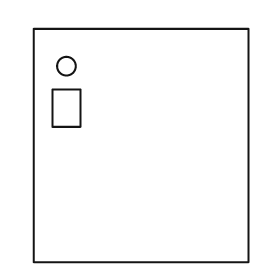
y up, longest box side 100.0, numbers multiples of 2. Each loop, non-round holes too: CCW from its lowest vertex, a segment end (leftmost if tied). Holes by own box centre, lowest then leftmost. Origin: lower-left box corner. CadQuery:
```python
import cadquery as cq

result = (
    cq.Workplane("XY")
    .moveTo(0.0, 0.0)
    .lineTo(92.0, 0.0)
    .lineTo(92.0, 100.0)
    .lineTo(0.0, 100.0)
    .close()
    .moveTo(8.0, 58.0)
    .lineTo(20.0, 58.0)
    .lineTo(20.0, 74.0)
    .lineTo(8.0, 74.0)
    .close()
    .moveTo(14.0, 84.0)
    .circle(4.0)
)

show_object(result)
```